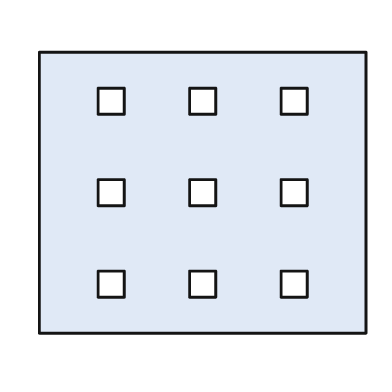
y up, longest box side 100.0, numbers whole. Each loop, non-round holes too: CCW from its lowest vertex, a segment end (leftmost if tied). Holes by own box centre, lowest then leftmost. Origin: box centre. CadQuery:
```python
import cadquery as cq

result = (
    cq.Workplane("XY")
    .moveTo(-50.0, -43.0)
    .lineTo(50.0, -43.0)
    .lineTo(50.0, 43.0)
    .lineTo(-50.0, 43.0)
    .close()
    .moveTo(-32.0, -32.0)
    .lineTo(-24.0, -32.0)
    .lineTo(-24.0, -24.0)
    .lineTo(-32.0, -24.0)
    .close()
    .moveTo(-4.0, -32.0)
    .lineTo(4.0, -32.0)
    .lineTo(4.0, -24.0)
    .lineTo(-4.0, -24.0)
    .close()
    .moveTo(24.0, -32.0)
    .lineTo(32.0, -32.0)
    .lineTo(32.0, -24.0)
    .lineTo(24.0, -24.0)
    .close()
    .moveTo(-32.0, -4.0)
    .lineTo(-24.0, -4.0)
    .lineTo(-24.0, 4.0)
    .lineTo(-32.0, 4.0)
    .close()
    .moveTo(-4.0, -4.0)
    .lineTo(4.0, -4.0)
    .lineTo(4.0, 4.0)
    .lineTo(-4.0, 4.0)
    .close()
    .moveTo(24.0, -4.0)
    .lineTo(32.0, -4.0)
    .lineTo(32.0, 4.0)
    .lineTo(24.0, 4.0)
    .close()
    .moveTo(-32.0, 24.0)
    .lineTo(-24.0, 24.0)
    .lineTo(-24.0, 32.0)
    .lineTo(-32.0, 32.0)
    .close()
    .moveTo(-4.0, 24.0)
    .lineTo(4.0, 24.0)
    .lineTo(4.0, 32.0)
    .lineTo(-4.0, 32.0)
    .close()
    .moveTo(24.0, 24.0)
    .lineTo(32.0, 24.0)
    .lineTo(32.0, 32.0)
    .lineTo(24.0, 32.0)
    .close()
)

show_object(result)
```